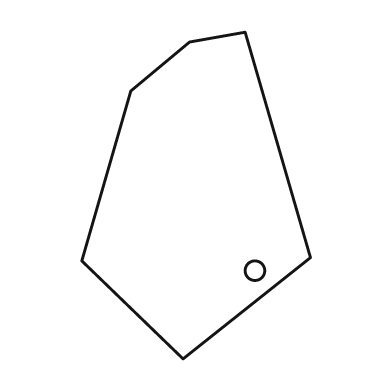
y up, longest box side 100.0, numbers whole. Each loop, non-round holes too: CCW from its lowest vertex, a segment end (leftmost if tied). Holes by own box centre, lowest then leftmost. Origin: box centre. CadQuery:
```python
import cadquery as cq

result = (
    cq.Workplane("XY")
    .moveTo(-4.0, -50.0)
    .lineTo(35.0, -19.0)
    .lineTo(15.0, 50.0)
    .lineTo(-2.0, 47.0)
    .lineTo(-20.0, 32.0)
    .lineTo(-35.0, -20.0)
    .close()
    .moveTo(18.0, -23.0)
    .circle(3.0)
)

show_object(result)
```